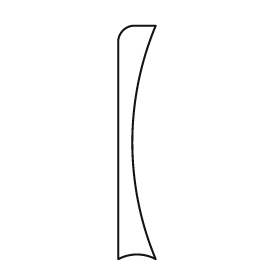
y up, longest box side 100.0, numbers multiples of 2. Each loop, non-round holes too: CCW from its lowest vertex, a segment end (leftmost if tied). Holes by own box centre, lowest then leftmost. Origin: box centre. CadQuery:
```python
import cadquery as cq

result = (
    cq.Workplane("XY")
    .moveTo(-8.0, -50.0)
    .threePointArc((0.0, -48.0), (8.0, -50.0))
    .threePointArc((-2.0, 0.0), (8.0, 50.0))
    .lineTo(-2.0, 50.0)
    .threePointArc((-6.0, 48.0), (-8.0, 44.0))
    .close()
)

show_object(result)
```